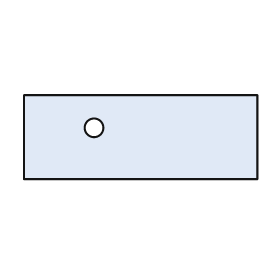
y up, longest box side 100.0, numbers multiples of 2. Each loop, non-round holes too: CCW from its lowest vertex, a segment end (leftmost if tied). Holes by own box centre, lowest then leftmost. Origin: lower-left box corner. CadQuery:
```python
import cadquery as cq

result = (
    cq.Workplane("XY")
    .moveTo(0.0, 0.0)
    .lineTo(100.0, 0.0)
    .lineTo(100.0, 36.0)
    .lineTo(0.0, 36.0)
    .close()
    .moveTo(30.0, 22.0)
    .circle(4.0)
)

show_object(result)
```